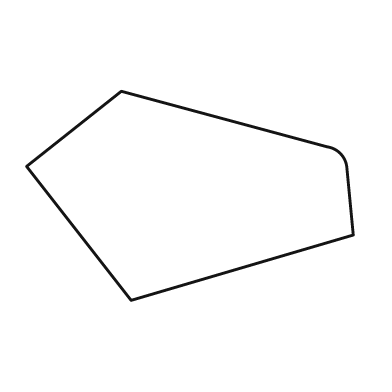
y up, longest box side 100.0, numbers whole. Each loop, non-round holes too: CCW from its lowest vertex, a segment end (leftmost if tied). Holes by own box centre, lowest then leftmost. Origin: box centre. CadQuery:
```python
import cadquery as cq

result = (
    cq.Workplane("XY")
    .moveTo(-18.0, -32.0)
    .lineTo(50.0, -12.0)
    .lineTo(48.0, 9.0)
    .threePointArc((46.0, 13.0), (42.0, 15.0))
    .lineTo(-21.0, 32.0)
    .lineTo(-50.0, 9.0)
    .close()
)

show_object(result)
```